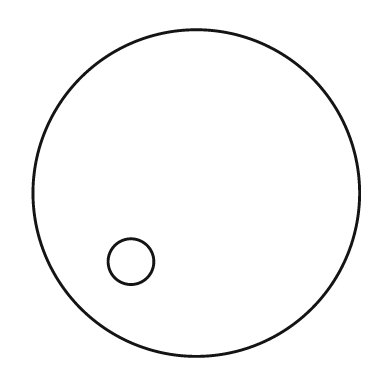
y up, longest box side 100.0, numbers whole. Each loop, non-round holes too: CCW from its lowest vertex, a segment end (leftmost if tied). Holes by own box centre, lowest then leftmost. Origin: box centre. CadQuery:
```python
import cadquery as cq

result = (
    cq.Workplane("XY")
    .moveTo(0.0, 0.0)
    .circle(50.0)
    .moveTo(-20.0, -21.0)
    .circle(7.0)
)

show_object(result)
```